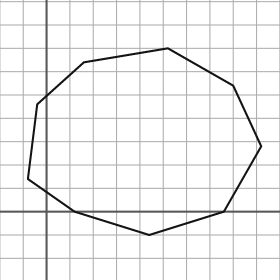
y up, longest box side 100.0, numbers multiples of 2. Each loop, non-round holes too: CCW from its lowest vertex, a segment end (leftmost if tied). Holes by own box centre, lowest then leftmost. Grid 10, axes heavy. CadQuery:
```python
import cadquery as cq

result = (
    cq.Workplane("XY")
    .moveTo(44.0, -10.0)
    .lineTo(76.0, 0.0)
    .lineTo(92.0, 28.0)
    .lineTo(80.0, 54.0)
    .lineTo(52.0, 70.0)
    .lineTo(16.0, 64.0)
    .lineTo(-4.0, 46.0)
    .lineTo(-8.0, 14.0)
    .lineTo(12.0, 0.0)
    .close()
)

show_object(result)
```